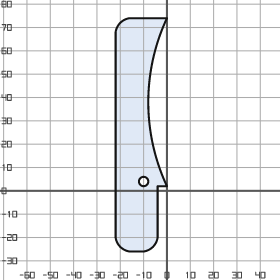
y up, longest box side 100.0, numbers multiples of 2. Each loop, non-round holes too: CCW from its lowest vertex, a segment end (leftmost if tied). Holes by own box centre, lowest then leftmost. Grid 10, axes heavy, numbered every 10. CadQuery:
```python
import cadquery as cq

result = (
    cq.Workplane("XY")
    .moveTo(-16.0, -26.0)
    .lineTo(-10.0, -26.0)
    .threePointArc((-6.0, -24.0), (-4.0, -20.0))
    .lineTo(-4.0, 2.0)
    .lineTo(0.0, 2.0)
    .threePointArc((-8.0, 38.0), (0.0, 74.0))
    .lineTo(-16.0, 74.0)
    .threePointArc((-20.0, 72.0), (-22.0, 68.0))
    .lineTo(-22.0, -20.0)
    .threePointArc((-20.0, -24.0), (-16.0, -26.0))
    .close()
    .moveTo(-10.0, 4.0)
    .circle(2.0)
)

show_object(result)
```